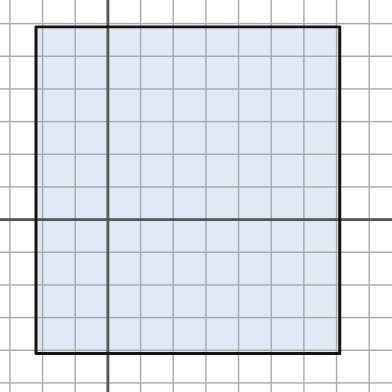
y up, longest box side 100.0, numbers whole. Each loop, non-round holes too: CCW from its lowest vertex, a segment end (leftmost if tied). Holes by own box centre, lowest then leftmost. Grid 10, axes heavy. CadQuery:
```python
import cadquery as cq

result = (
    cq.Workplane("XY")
    .moveTo(-22.0, -41.0)
    .lineTo(71.0, -41.0)
    .lineTo(71.0, 59.0)
    .lineTo(-22.0, 59.0)
    .close()
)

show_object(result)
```